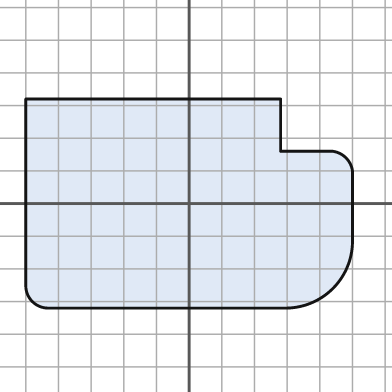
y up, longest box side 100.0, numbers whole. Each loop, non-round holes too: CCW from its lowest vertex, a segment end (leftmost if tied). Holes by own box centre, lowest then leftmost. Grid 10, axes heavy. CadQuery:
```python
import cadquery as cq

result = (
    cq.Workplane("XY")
    .moveTo(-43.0, -32.0)
    .lineTo(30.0, -32.0)
    .threePointArc((44.0, -26.0), (50.0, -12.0))
    .lineTo(50.0, 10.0)
    .threePointArc((48.0, 14.0), (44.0, 16.0))
    .lineTo(28.0, 16.0)
    .lineTo(28.0, 32.0)
    .lineTo(-50.0, 32.0)
    .lineTo(-50.0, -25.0)
    .threePointArc((-48.0, -30.0), (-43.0, -32.0))
    .close()
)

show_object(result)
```